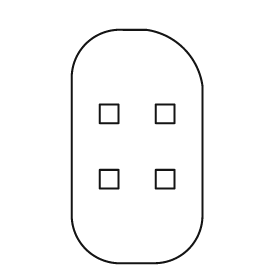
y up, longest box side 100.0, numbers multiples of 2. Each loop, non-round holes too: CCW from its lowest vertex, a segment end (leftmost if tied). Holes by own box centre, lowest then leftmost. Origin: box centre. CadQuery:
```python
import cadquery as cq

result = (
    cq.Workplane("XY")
    .moveTo(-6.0, -50.0)
    .lineTo(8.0, -50.0)
    .threePointArc((22.0, -44.0), (28.0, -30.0))
    .lineTo(28.0, 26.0)
    .threePointArc((20.0, 42.0), (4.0, 50.0))
    .lineTo(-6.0, 50.0)
    .threePointArc((-22.0, 44.0), (-28.0, 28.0))
    .lineTo(-28.0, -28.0)
    .threePointArc((-22.0, -44.0), (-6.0, -50.0))
    .close()
    .moveTo(-16.0, -18.0)
    .lineTo(-8.0, -18.0)
    .lineTo(-8.0, -10.0)
    .lineTo(-16.0, -10.0)
    .close()
    .moveTo(8.0, -18.0)
    .lineTo(16.0, -18.0)
    .lineTo(16.0, -10.0)
    .lineTo(8.0, -10.0)
    .close()
    .moveTo(-16.0, 10.0)
    .lineTo(-8.0, 10.0)
    .lineTo(-8.0, 18.0)
    .lineTo(-16.0, 18.0)
    .close()
    .moveTo(8.0, 10.0)
    .lineTo(16.0, 10.0)
    .lineTo(16.0, 18.0)
    .lineTo(8.0, 18.0)
    .close()
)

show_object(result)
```